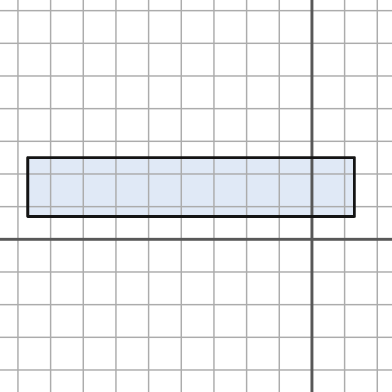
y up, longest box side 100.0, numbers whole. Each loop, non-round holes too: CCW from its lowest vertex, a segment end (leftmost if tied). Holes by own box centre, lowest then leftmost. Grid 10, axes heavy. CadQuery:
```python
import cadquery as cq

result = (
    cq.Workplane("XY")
    .moveTo(-87.0, 7.0)
    .lineTo(13.0, 7.0)
    .lineTo(13.0, 25.0)
    .lineTo(-87.0, 25.0)
    .close()
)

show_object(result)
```